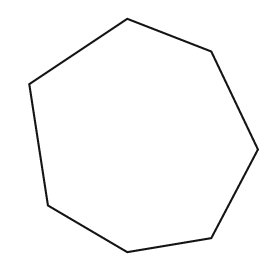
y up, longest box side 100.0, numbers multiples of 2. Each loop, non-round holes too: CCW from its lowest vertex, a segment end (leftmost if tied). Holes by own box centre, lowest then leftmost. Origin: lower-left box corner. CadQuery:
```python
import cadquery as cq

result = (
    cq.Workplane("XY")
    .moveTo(42.0, 0.0)
    .lineTo(78.0, 6.0)
    .lineTo(98.0, 44.0)
    .lineTo(78.0, 86.0)
    .lineTo(42.0, 100.0)
    .lineTo(0.0, 72.0)
    .lineTo(8.0, 20.0)
    .close()
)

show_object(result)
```